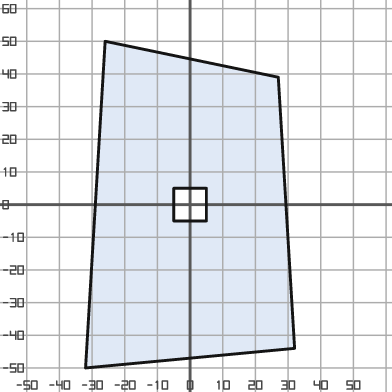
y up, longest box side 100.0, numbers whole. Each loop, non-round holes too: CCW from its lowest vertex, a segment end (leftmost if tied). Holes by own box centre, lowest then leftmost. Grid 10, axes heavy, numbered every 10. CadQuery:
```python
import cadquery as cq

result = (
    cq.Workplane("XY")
    .moveTo(-32.0, -50.0)
    .lineTo(32.0, -44.0)
    .lineTo(27.0, 39.0)
    .lineTo(-26.0, 50.0)
    .close()
    .moveTo(-5.0, -5.0)
    .lineTo(5.0, -5.0)
    .lineTo(5.0, 5.0)
    .lineTo(-5.0, 5.0)
    .close()
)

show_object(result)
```